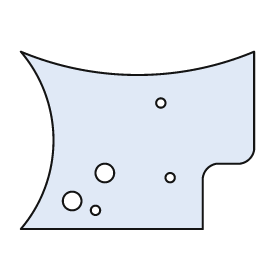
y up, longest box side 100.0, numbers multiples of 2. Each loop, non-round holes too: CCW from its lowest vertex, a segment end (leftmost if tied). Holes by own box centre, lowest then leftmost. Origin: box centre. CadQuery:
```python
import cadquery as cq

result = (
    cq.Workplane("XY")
    .moveTo(-50.0, -38.0)
    .lineTo(28.0, -38.0)
    .lineTo(28.0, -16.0)
    .threePointArc((30.0, -12.0), (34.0, -10.0))
    .lineTo(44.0, -10.0)
    .threePointArc((48.0, -8.0), (50.0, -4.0))
    .lineTo(50.0, 38.0)
    .threePointArc((0.0, 28.0), (-50.0, 38.0))
    .threePointArc((-36.0, 0.0), (-50.0, -38.0))
    .close()
    .moveTo(-18.0, -30.0)
    .circle(2.0)
    .moveTo(-28.0, -26.0)
    .circle(4.0)
    .moveTo(14.0, -16.0)
    .circle(2.0)
    .moveTo(-14.0, -14.0)
    .circle(4.0)
    .moveTo(10.0, 16.0)
    .circle(2.0)
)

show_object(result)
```